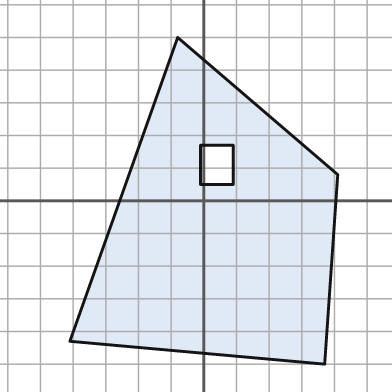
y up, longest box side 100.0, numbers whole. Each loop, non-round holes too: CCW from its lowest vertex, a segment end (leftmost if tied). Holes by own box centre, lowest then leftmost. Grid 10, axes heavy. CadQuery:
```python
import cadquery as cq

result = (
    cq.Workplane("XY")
    .moveTo(37.0, -50.0)
    .lineTo(41.0, 8.0)
    .lineTo(-8.0, 50.0)
    .lineTo(-41.0, -43.0)
    .close()
    .moveTo(-1.0, 5.0)
    .lineTo(9.0, 5.0)
    .lineTo(9.0, 17.0)
    .lineTo(-1.0, 17.0)
    .close()
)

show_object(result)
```